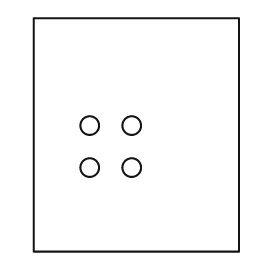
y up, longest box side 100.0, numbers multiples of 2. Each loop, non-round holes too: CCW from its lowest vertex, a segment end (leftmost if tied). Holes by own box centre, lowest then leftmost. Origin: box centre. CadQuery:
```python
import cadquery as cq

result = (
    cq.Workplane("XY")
    .moveTo(-44.0, -50.0)
    .lineTo(44.0, -50.0)
    .lineTo(44.0, 50.0)
    .lineTo(-44.0, 50.0)
    .close()
    .moveTo(-20.0, -14.0)
    .circle(4.0)
    .moveTo(-2.0, -14.0)
    .circle(4.0)
    .moveTo(-20.0, 4.0)
    .circle(4.0)
    .moveTo(-2.0, 4.0)
    .circle(4.0)
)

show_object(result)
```